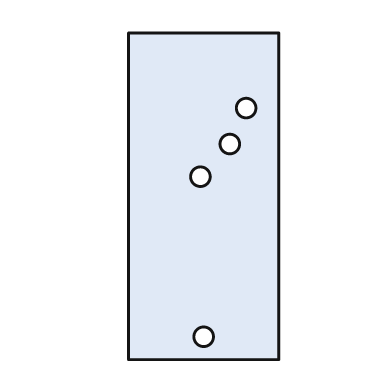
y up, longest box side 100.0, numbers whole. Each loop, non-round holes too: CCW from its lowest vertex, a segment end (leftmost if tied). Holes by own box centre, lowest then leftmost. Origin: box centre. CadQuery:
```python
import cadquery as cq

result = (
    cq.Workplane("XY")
    .moveTo(-23.0, -50.0)
    .lineTo(23.0, -50.0)
    .lineTo(23.0, 50.0)
    .lineTo(-23.0, 50.0)
    .close()
    .moveTo(0.0, -43.0)
    .circle(3.0)
    .moveTo(-1.0, 6.0)
    .circle(3.0)
    .moveTo(8.0, 16.0)
    .circle(3.0)
    .moveTo(13.0, 27.0)
    .circle(3.0)
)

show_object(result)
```